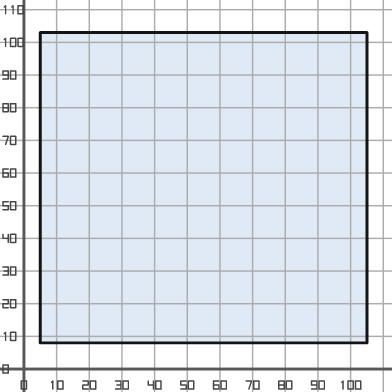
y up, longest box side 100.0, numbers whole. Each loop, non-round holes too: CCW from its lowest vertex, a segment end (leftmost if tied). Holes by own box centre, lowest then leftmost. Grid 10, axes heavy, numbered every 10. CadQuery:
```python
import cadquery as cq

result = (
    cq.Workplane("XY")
    .moveTo(5.0, 8.0)
    .lineTo(105.0, 8.0)
    .lineTo(105.0, 103.0)
    .lineTo(5.0, 103.0)
    .close()
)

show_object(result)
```